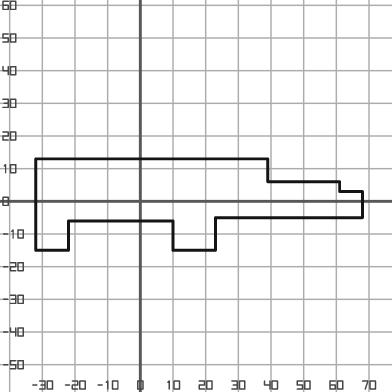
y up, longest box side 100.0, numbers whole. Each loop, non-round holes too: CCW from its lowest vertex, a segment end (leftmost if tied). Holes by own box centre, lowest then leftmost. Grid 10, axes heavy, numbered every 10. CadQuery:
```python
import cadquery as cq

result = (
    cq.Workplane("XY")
    .moveTo(-32.0, -15.0)
    .lineTo(-22.0, -15.0)
    .lineTo(-22.0, -6.0)
    .lineTo(10.0, -6.0)
    .lineTo(10.0, -15.0)
    .lineTo(23.0, -15.0)
    .lineTo(23.0, -5.0)
    .lineTo(68.0, -5.0)
    .lineTo(68.0, 3.0)
    .lineTo(61.0, 3.0)
    .lineTo(61.0, 6.0)
    .lineTo(39.0, 6.0)
    .lineTo(39.0, 13.0)
    .lineTo(-32.0, 13.0)
    .close()
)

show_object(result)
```